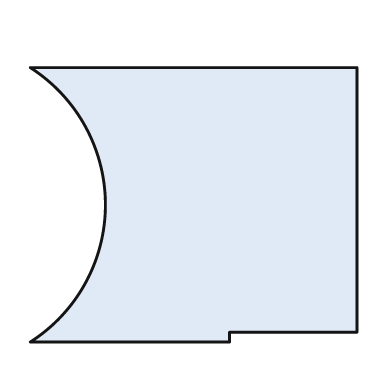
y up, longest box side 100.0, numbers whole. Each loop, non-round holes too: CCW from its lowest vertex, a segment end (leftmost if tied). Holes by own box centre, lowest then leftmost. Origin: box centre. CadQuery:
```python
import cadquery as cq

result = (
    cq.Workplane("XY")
    .moveTo(-50.0, -42.0)
    .lineTo(11.0, -42.0)
    .lineTo(11.0, -39.0)
    .lineTo(50.0, -39.0)
    .lineTo(50.0, 42.0)
    .lineTo(-50.0, 42.0)
    .threePointArc((-27.0, 0.0), (-50.0, -42.0))
    .close()
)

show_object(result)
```